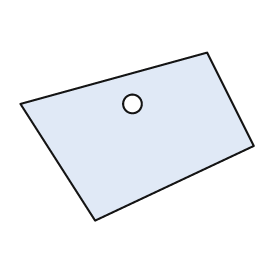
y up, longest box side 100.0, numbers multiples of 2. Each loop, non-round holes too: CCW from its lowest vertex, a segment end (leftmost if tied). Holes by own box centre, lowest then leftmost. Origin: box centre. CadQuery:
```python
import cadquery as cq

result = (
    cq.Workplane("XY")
    .moveTo(-18.0, -36.0)
    .lineTo(50.0, -4.0)
    .lineTo(30.0, 36.0)
    .lineTo(-50.0, 14.0)
    .close()
    .moveTo(-2.0, 14.0)
    .circle(4.0)
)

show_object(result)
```